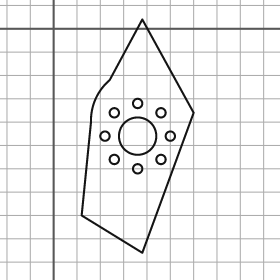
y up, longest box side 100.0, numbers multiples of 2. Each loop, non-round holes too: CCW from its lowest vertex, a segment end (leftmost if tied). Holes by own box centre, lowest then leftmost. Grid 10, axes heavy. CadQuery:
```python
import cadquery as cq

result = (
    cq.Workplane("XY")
    .moveTo(38.0, -96.0)
    .lineTo(60.0, -36.0)
    .lineTo(38.0, 4.0)
    .lineTo(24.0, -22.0)
    .threePointArc((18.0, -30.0), (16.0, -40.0))
    .lineTo(12.0, -80.0)
    .close()
    .moveTo(36.0, -60.0)
    .circle(2.0)
    .moveTo(26.0, -56.0)
    .circle(2.0)
    .moveTo(46.0, -56.0)
    .circle(2.0)
    .moveTo(22.0, -46.0)
    .circle(2.0)
    .moveTo(36.0, -46.0)
    .circle(8.0)
    .moveTo(50.0, -46.0)
    .circle(2.0)
    .moveTo(26.0, -36.0)
    .circle(2.0)
    .moveTo(46.0, -36.0)
    .circle(2.0)
    .moveTo(36.0, -32.0)
    .circle(2.0)
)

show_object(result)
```